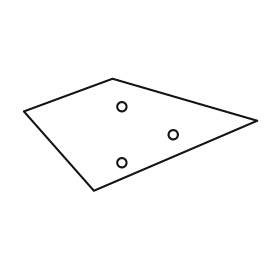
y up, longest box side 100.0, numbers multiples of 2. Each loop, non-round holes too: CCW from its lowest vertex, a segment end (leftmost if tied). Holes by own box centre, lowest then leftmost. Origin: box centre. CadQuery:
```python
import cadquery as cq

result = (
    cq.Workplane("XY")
    .moveTo(-20.0, -24.0)
    .lineTo(50.0, 6.0)
    .lineTo(-12.0, 24.0)
    .lineTo(-50.0, 10.0)
    .close()
    .moveTo(-8.0, -12.0)
    .circle(2.0)
    .moveTo(14.0, 0.0)
    .circle(2.0)
    .moveTo(-8.0, 12.0)
    .circle(2.0)
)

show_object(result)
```